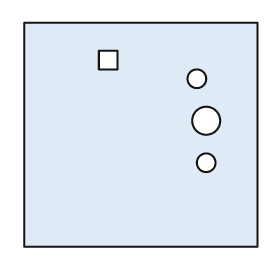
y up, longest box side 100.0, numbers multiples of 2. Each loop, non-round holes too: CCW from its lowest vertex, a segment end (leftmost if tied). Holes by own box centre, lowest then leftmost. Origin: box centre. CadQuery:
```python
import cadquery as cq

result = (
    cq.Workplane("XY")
    .moveTo(-50.0, -48.0)
    .lineTo(50.0, -48.0)
    .lineTo(50.0, 48.0)
    .lineTo(-50.0, 48.0)
    .close()
    .moveTo(28.0, -12.0)
    .circle(4.0)
    .moveTo(28.0, 6.0)
    .circle(6.0)
    .moveTo(24.0, 24.0)
    .circle(4.0)
    .moveTo(-18.0, 28.0)
    .lineTo(-10.0, 28.0)
    .lineTo(-10.0, 36.0)
    .lineTo(-18.0, 36.0)
    .close()
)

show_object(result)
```